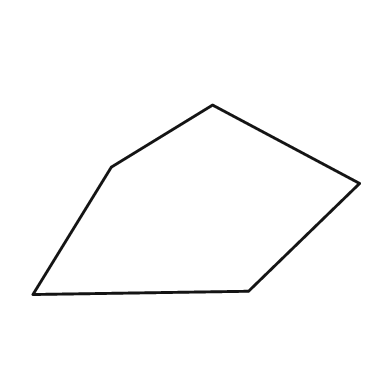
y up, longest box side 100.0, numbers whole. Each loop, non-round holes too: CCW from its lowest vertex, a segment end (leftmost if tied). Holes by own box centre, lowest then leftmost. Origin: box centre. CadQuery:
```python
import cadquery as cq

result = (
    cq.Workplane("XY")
    .moveTo(-50.0, -29.0)
    .lineTo(16.0, -28.0)
    .lineTo(50.0, 5.0)
    .lineTo(5.0, 29.0)
    .lineTo(-26.0, 10.0)
    .close()
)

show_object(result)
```